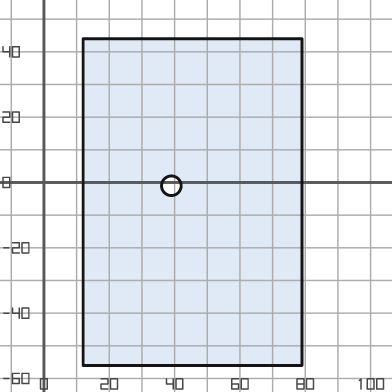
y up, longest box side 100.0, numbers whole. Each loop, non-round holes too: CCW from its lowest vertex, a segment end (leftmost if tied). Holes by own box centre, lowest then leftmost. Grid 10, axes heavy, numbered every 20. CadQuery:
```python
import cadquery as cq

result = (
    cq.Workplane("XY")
    .moveTo(12.0, -56.0)
    .lineTo(79.0, -56.0)
    .lineTo(79.0, 44.0)
    .lineTo(12.0, 44.0)
    .close()
    .moveTo(39.0, -1.0)
    .circle(3.0)
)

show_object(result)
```